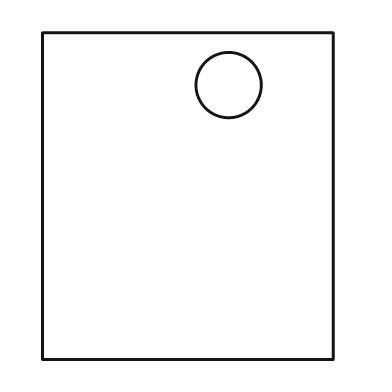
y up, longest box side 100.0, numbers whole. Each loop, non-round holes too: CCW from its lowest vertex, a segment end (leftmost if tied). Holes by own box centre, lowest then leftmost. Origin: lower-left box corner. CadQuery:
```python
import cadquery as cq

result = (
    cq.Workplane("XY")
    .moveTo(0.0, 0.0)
    .lineTo(89.0, 0.0)
    .lineTo(89.0, 100.0)
    .lineTo(0.0, 100.0)
    .close()
    .moveTo(57.0, 84.0)
    .circle(10.0)
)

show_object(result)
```